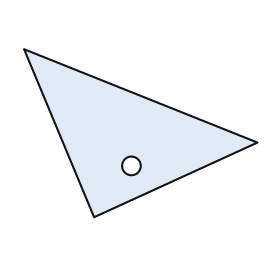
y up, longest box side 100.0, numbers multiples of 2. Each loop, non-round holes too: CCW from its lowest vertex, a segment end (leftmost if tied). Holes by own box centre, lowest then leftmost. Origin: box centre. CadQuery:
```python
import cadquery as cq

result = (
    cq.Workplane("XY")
    .moveTo(-20.0, -36.0)
    .lineTo(50.0, -4.0)
    .lineTo(-50.0, 36.0)
    .close()
    .moveTo(-4.0, -14.0)
    .circle(4.0)
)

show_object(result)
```